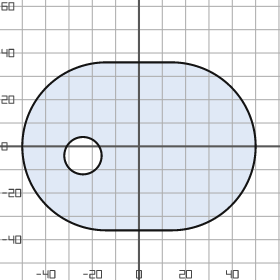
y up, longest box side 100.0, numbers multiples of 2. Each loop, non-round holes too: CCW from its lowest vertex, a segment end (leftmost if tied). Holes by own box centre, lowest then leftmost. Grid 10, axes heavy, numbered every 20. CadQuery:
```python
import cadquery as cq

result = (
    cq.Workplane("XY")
    .moveTo(-14.0, -36.0)
    .lineTo(14.0, -36.0)
    .threePointArc((50.0, 0.0), (14.0, 36.0))
    .lineTo(-14.0, 36.0)
    .threePointArc((-50.0, 0.0), (-14.0, -36.0))
    .close()
    .moveTo(-24.0, -4.0)
    .circle(8.0)
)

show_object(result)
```